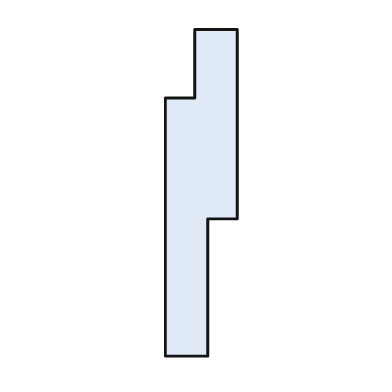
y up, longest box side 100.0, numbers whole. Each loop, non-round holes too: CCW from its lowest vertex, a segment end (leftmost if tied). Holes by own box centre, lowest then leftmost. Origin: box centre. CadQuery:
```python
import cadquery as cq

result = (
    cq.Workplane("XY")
    .moveTo(-11.0, -50.0)
    .lineTo(2.0, -50.0)
    .lineTo(2.0, -8.0)
    .lineTo(11.0, -8.0)
    .lineTo(11.0, 50.0)
    .lineTo(-2.0, 50.0)
    .lineTo(-2.0, 29.0)
    .lineTo(-11.0, 29.0)
    .close()
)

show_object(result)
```